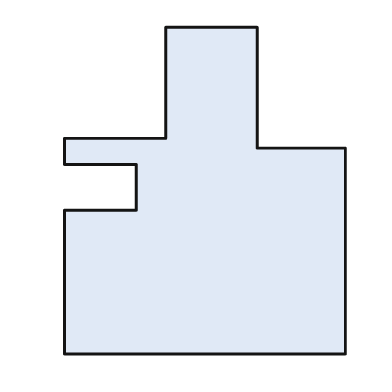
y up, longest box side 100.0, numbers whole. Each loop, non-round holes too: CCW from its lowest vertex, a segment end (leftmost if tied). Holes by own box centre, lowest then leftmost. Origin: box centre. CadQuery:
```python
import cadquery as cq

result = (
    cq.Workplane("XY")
    .moveTo(-43.0, -50.0)
    .lineTo(43.0, -50.0)
    .lineTo(43.0, 13.0)
    .lineTo(16.0, 13.0)
    .lineTo(16.0, 50.0)
    .lineTo(-12.0, 50.0)
    .lineTo(-12.0, 16.0)
    .lineTo(-43.0, 16.0)
    .lineTo(-43.0, 8.0)
    .lineTo(-21.0, 8.0)
    .lineTo(-21.0, -6.0)
    .lineTo(-43.0, -6.0)
    .close()
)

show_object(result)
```